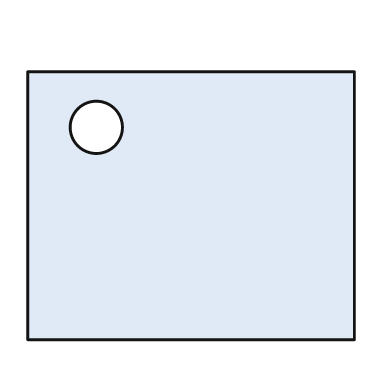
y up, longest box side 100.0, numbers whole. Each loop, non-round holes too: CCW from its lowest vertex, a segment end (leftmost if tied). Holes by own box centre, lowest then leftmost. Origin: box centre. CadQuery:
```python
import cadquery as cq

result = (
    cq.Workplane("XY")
    .moveTo(-50.0, -41.0)
    .lineTo(50.0, -41.0)
    .lineTo(50.0, 41.0)
    .lineTo(-50.0, 41.0)
    .close()
    .moveTo(-29.0, 24.0)
    .circle(8.0)
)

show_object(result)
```